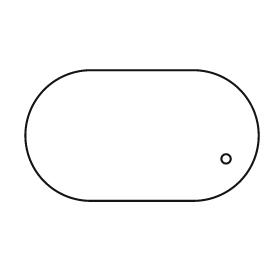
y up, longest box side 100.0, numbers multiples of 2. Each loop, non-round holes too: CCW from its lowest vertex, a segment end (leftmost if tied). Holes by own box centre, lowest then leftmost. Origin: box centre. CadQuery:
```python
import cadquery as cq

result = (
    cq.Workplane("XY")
    .moveTo(-22.0, -28.0)
    .lineTo(22.0, -28.0)
    .threePointArc((50.0, 0.0), (22.0, 28.0))
    .lineTo(-22.0, 28.0)
    .threePointArc((-50.0, 0.0), (-22.0, -28.0))
    .close()
    .moveTo(36.0, -10.0)
    .circle(2.0)
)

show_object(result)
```